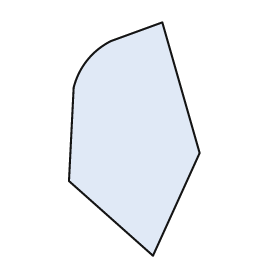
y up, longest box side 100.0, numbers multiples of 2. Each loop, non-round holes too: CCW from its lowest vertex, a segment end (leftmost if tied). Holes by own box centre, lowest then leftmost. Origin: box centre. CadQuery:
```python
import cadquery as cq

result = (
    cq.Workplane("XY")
    .moveTo(8.0, -50.0)
    .lineTo(28.0, -6.0)
    .lineTo(12.0, 50.0)
    .lineTo(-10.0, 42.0)
    .threePointArc((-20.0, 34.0), (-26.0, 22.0))
    .lineTo(-28.0, -18.0)
    .close()
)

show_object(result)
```